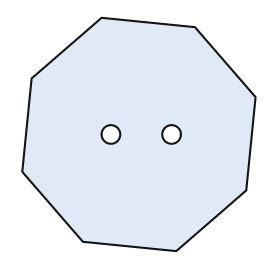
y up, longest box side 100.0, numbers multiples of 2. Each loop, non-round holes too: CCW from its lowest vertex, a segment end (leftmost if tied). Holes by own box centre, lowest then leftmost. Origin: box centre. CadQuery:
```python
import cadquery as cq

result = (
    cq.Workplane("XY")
    .moveTo(16.0, -50.0)
    .lineTo(46.0, -24.0)
    .lineTo(50.0, 16.0)
    .lineTo(24.0, 46.0)
    .lineTo(-16.0, 50.0)
    .lineTo(-46.0, 24.0)
    .lineTo(-50.0, -16.0)
    .lineTo(-24.0, -46.0)
    .close()
    .moveTo(-12.0, 0.0)
    .circle(4.0)
    .moveTo(14.0, 0.0)
    .circle(4.0)
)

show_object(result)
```